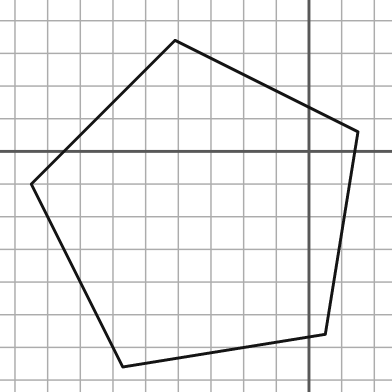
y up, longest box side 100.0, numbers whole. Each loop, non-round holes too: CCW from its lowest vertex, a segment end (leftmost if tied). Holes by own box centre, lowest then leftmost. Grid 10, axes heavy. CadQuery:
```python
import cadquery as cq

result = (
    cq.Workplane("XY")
    .moveTo(-57.0, -66.0)
    .lineTo(5.0, -56.0)
    .lineTo(15.0, 6.0)
    .lineTo(-41.0, 34.0)
    .lineTo(-85.0, -10.0)
    .close()
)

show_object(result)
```